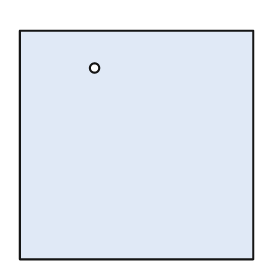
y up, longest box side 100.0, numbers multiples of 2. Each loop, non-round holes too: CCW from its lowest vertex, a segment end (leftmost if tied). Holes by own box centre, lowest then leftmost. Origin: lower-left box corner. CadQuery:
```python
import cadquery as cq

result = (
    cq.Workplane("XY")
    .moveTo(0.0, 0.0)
    .lineTo(100.0, 0.0)
    .lineTo(100.0, 98.0)
    .lineTo(0.0, 98.0)
    .close()
    .moveTo(32.0, 82.0)
    .circle(2.0)
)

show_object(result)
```